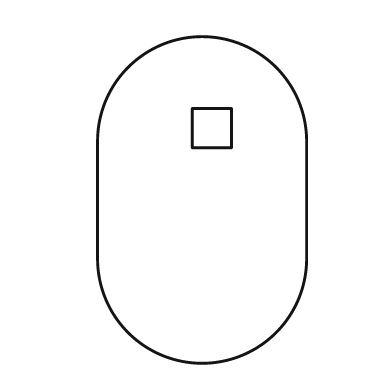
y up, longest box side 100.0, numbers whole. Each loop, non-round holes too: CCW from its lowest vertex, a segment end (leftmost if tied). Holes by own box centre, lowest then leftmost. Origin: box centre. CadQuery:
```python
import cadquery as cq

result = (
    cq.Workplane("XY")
    .moveTo(-32.0, -18.0)
    .threePointArc((0.0, -50.0), (32.0, -18.0))
    .lineTo(32.0, 18.0)
    .threePointArc((0.0, 50.0), (-32.0, 18.0))
    .close()
    .moveTo(-3.0, 16.0)
    .lineTo(9.0, 16.0)
    .lineTo(9.0, 28.0)
    .lineTo(-3.0, 28.0)
    .close()
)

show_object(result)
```